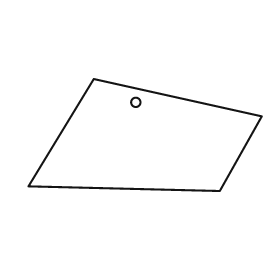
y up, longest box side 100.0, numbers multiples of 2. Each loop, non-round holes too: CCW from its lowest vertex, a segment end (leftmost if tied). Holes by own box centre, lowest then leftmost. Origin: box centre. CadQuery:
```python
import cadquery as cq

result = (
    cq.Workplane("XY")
    .moveTo(32.0, -24.0)
    .lineTo(50.0, 8.0)
    .lineTo(-22.0, 24.0)
    .lineTo(-50.0, -22.0)
    .close()
    .moveTo(-4.0, 14.0)
    .circle(2.0)
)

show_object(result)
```